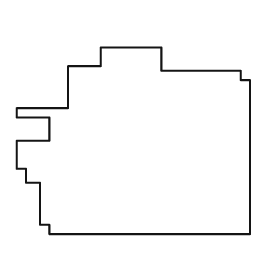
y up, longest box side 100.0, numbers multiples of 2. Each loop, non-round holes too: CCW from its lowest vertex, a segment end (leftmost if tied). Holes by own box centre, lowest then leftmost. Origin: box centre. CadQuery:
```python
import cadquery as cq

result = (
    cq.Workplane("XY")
    .moveTo(-36.0, -40.0)
    .lineTo(50.0, -40.0)
    .lineTo(50.0, 26.0)
    .lineTo(46.0, 26.0)
    .lineTo(46.0, 30.0)
    .lineTo(12.0, 30.0)
    .lineTo(12.0, 40.0)
    .lineTo(-14.0, 40.0)
    .lineTo(-14.0, 32.0)
    .lineTo(-28.0, 32.0)
    .lineTo(-28.0, 14.0)
    .lineTo(-50.0, 14.0)
    .lineTo(-50.0, 10.0)
    .lineTo(-36.0, 10.0)
    .lineTo(-36.0, 0.0)
    .lineTo(-50.0, 0.0)
    .lineTo(-50.0, -12.0)
    .lineTo(-46.0, -12.0)
    .lineTo(-46.0, -18.0)
    .lineTo(-40.0, -18.0)
    .lineTo(-40.0, -36.0)
    .lineTo(-36.0, -36.0)
    .close()
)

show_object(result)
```